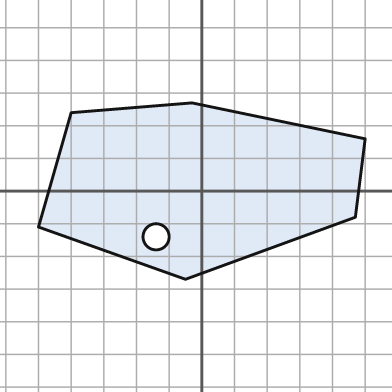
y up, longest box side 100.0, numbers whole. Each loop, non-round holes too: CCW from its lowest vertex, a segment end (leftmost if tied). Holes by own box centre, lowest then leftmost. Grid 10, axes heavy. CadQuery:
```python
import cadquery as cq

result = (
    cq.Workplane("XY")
    .moveTo(-5.0, -27.0)
    .lineTo(47.0, -8.0)
    .lineTo(50.0, 16.0)
    .lineTo(-3.0, 27.0)
    .lineTo(-40.0, 24.0)
    .lineTo(-50.0, -11.0)
    .close()
    .moveTo(-14.0, -14.0)
    .circle(4.0)
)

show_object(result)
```